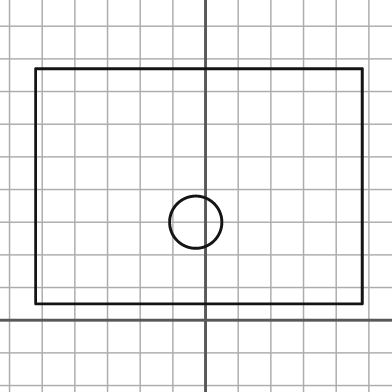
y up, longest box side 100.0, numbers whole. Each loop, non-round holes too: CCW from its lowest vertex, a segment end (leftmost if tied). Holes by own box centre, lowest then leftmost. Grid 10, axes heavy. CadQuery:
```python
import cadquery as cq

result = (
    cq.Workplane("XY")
    .moveTo(-52.0, 5.0)
    .lineTo(48.0, 5.0)
    .lineTo(48.0, 77.0)
    .lineTo(-52.0, 77.0)
    .close()
    .moveTo(-3.0, 30.0)
    .circle(8.0)
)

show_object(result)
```